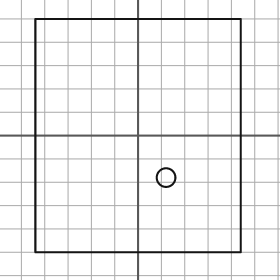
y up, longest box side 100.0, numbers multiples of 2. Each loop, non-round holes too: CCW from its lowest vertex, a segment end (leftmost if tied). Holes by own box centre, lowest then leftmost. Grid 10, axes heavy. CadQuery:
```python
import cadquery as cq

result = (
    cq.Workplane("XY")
    .moveTo(-44.0, -50.0)
    .lineTo(44.0, -50.0)
    .lineTo(44.0, 50.0)
    .lineTo(-44.0, 50.0)
    .close()
    .moveTo(12.0, -18.0)
    .circle(4.0)
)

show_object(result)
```